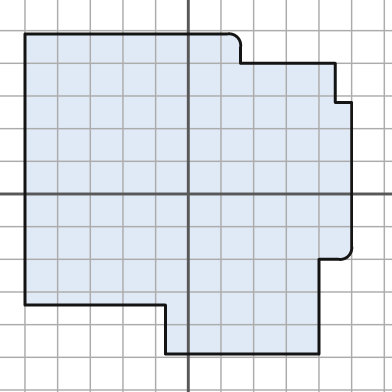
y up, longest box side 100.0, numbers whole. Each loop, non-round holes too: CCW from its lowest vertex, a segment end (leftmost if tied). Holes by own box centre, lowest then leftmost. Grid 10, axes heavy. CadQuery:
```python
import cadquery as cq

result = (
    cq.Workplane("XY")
    .moveTo(-7.0, -49.0)
    .lineTo(40.0, -49.0)
    .lineTo(40.0, -20.0)
    .lineTo(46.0, -20.0)
    .threePointArc((49.0, -19.0), (50.0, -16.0))
    .lineTo(50.0, 28.0)
    .lineTo(45.0, 28.0)
    .lineTo(45.0, 40.0)
    .lineTo(16.0, 40.0)
    .lineTo(16.0, 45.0)
    .threePointArc((15.0, 48.0), (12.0, 49.0))
    .lineTo(-50.0, 49.0)
    .lineTo(-50.0, -34.0)
    .lineTo(-7.0, -34.0)
    .close()
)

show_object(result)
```